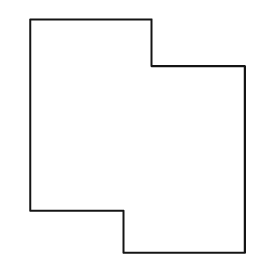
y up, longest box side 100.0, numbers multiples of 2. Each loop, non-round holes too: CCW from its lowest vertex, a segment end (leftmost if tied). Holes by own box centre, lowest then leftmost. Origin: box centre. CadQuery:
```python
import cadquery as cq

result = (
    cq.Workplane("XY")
    .moveTo(-6.0, -50.0)
    .lineTo(46.0, -50.0)
    .lineTo(46.0, 30.0)
    .lineTo(6.0, 30.0)
    .lineTo(6.0, 50.0)
    .lineTo(-46.0, 50.0)
    .lineTo(-46.0, -32.0)
    .lineTo(-6.0, -32.0)
    .close()
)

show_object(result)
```